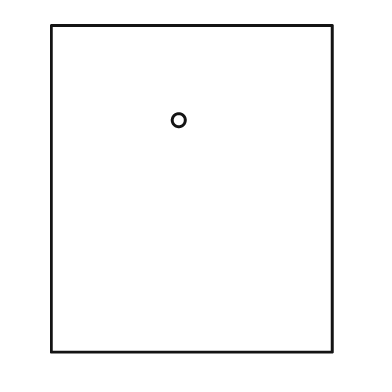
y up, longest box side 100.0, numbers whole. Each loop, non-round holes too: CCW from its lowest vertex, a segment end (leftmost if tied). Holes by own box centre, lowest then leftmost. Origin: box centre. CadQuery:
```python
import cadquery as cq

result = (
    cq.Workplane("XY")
    .moveTo(-43.0, -50.0)
    .lineTo(43.0, -50.0)
    .lineTo(43.0, 50.0)
    .lineTo(-43.0, 50.0)
    .close()
    .moveTo(-4.0, 21.0)
    .circle(2.0)
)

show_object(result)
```